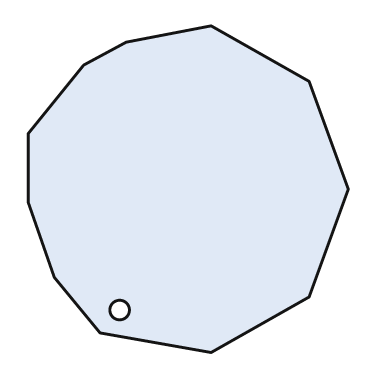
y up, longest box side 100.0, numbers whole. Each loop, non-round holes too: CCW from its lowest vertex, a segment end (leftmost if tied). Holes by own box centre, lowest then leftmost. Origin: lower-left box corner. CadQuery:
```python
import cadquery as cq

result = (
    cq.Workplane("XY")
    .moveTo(56.0, 0.0)
    .lineTo(86.0, 17.0)
    .lineTo(98.0, 50.0)
    .lineTo(86.0, 83.0)
    .lineTo(56.0, 100.0)
    .lineTo(30.0, 95.0)
    .lineTo(17.0, 88.0)
    .lineTo(0.0, 67.0)
    .lineTo(0.0, 46.0)
    .lineTo(8.0, 23.0)
    .lineTo(22.0, 6.0)
    .close()
    .moveTo(28.0, 13.0)
    .circle(3.0)
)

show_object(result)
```